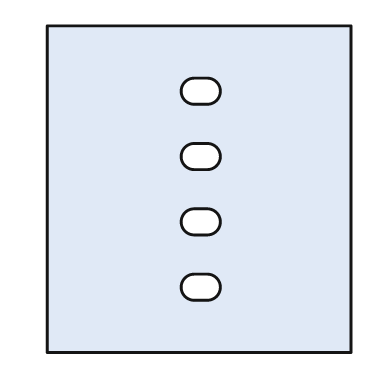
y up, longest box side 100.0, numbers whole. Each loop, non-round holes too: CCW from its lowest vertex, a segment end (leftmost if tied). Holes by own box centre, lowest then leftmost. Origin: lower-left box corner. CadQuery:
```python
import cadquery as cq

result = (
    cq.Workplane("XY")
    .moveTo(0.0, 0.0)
    .lineTo(93.0, 0.0)
    .lineTo(93.0, 100.0)
    .lineTo(0.0, 100.0)
    .close()
    .moveTo(45.0, 16.0)
    .lineTo(49.0, 16.0)
    .threePointArc((53.0, 20.0), (49.0, 24.0))
    .lineTo(45.0, 24.0)
    .threePointArc((41.0, 20.0), (45.0, 16.0))
    .close()
    .moveTo(45.0, 36.0)
    .lineTo(49.0, 36.0)
    .threePointArc((53.0, 40.0), (49.0, 44.0))
    .lineTo(45.0, 44.0)
    .threePointArc((41.0, 40.0), (45.0, 36.0))
    .close()
    .moveTo(45.0, 56.0)
    .lineTo(49.0, 56.0)
    .threePointArc((53.0, 60.0), (49.0, 64.0))
    .lineTo(45.0, 64.0)
    .threePointArc((41.0, 60.0), (45.0, 56.0))
    .close()
    .moveTo(45.0, 76.0)
    .lineTo(49.0, 76.0)
    .threePointArc((53.0, 80.0), (49.0, 84.0))
    .lineTo(45.0, 84.0)
    .threePointArc((41.0, 80.0), (45.0, 76.0))
    .close()
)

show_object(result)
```